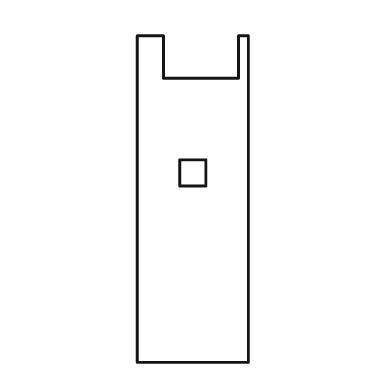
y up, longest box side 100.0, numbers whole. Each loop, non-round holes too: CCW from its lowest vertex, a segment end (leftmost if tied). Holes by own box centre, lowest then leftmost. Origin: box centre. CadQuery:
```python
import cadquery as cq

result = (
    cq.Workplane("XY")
    .moveTo(-17.0, -50.0)
    .lineTo(17.0, -50.0)
    .lineTo(17.0, 50.0)
    .lineTo(14.0, 50.0)
    .lineTo(14.0, 37.0)
    .lineTo(-9.0, 37.0)
    .lineTo(-9.0, 50.0)
    .lineTo(-17.0, 50.0)
    .close()
    .moveTo(-4.0, 4.0)
    .lineTo(4.0, 4.0)
    .lineTo(4.0, 12.0)
    .lineTo(-4.0, 12.0)
    .close()
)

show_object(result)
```